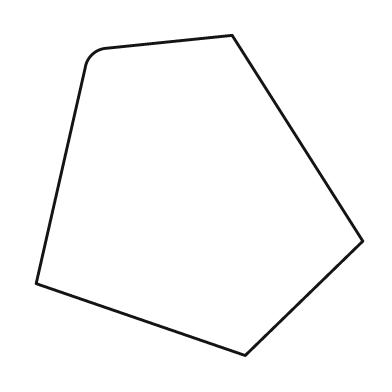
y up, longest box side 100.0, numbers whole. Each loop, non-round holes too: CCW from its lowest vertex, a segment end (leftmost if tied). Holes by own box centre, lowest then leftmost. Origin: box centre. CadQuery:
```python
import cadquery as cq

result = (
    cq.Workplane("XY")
    .moveTo(14.0, -49.0)
    .lineTo(50.0, -14.0)
    .lineTo(10.0, 49.0)
    .lineTo(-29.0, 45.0)
    .threePointArc((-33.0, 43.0), (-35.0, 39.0))
    .lineTo(-50.0, -27.0)
    .close()
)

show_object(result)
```